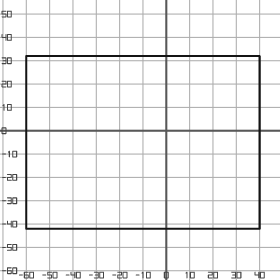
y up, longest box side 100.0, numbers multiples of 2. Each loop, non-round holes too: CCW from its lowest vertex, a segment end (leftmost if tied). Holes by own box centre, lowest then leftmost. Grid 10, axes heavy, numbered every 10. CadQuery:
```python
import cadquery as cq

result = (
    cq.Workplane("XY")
    .moveTo(-60.0, -42.0)
    .lineTo(40.0, -42.0)
    .lineTo(40.0, 32.0)
    .lineTo(-60.0, 32.0)
    .close()
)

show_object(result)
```